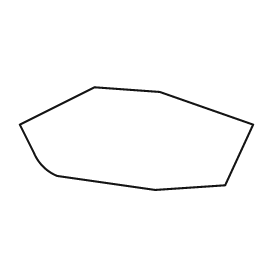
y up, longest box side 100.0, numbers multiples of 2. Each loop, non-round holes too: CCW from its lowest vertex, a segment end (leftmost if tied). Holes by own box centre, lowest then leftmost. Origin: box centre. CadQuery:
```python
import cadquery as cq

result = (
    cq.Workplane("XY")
    .moveTo(8.0, -22.0)
    .lineTo(38.0, -20.0)
    .lineTo(50.0, 6.0)
    .lineTo(10.0, 20.0)
    .lineTo(-18.0, 22.0)
    .lineTo(-50.0, 6.0)
    .lineTo(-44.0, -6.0)
    .threePointArc((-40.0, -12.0), (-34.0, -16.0))
    .close()
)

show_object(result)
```